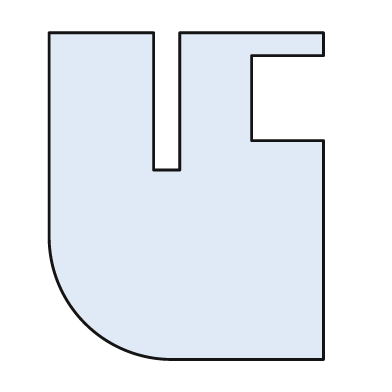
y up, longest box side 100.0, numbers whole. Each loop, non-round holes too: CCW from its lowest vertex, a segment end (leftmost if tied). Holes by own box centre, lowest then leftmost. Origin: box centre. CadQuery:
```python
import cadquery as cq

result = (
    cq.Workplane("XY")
    .moveTo(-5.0, -50.0)
    .lineTo(42.0, -50.0)
    .lineTo(42.0, 17.0)
    .lineTo(20.0, 17.0)
    .lineTo(20.0, 43.0)
    .lineTo(42.0, 43.0)
    .lineTo(42.0, 50.0)
    .lineTo(-2.0, 50.0)
    .lineTo(-2.0, 8.0)
    .lineTo(-10.0, 8.0)
    .lineTo(-10.0, 50.0)
    .lineTo(-42.0, 50.0)
    .lineTo(-42.0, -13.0)
    .threePointArc((-31.0, -39.0), (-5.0, -50.0))
    .close()
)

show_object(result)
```